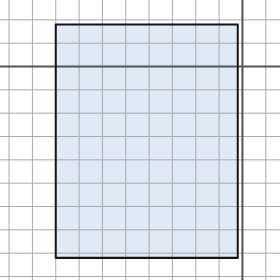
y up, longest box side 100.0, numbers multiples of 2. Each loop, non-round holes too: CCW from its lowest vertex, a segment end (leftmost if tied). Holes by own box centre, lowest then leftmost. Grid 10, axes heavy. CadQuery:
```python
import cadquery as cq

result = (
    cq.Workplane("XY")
    .moveTo(-80.0, -82.0)
    .lineTo(-2.0, -82.0)
    .lineTo(-2.0, 18.0)
    .lineTo(-80.0, 18.0)
    .close()
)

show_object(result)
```